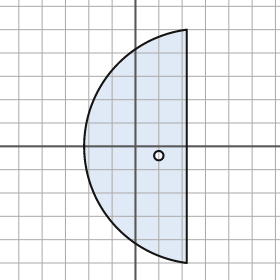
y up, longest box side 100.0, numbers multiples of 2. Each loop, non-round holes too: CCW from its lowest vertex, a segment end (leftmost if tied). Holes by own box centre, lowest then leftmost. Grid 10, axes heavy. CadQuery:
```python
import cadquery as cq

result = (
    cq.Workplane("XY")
    .moveTo(22.0, -50.0)
    .lineTo(22.0, 50.0)
    .threePointArc((-22.0, 0.0), (22.0, -50.0))
    .close()
    .moveTo(10.0, -4.0)
    .circle(2.0)
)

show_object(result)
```